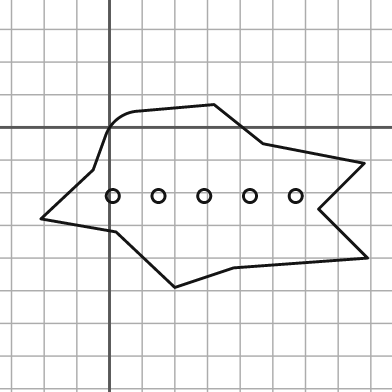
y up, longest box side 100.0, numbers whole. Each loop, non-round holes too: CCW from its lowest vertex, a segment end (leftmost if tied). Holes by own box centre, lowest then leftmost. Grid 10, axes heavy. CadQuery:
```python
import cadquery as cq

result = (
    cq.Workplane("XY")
    .moveTo(20.0, -49.0)
    .lineTo(38.0, -43.0)
    .lineTo(79.0, -40.0)
    .lineTo(64.0, -25.0)
    .lineTo(78.0, -11.0)
    .lineTo(47.0, -5.0)
    .lineTo(32.0, 7.0)
    .lineTo(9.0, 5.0)
    .threePointArc((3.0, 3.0), (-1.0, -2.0))
    .lineTo(-5.0, -13.0)
    .lineTo(-21.0, -28.0)
    .lineTo(2.0, -32.0)
    .close()
    .moveTo(1.0, -21.0)
    .circle(2.0)
    .moveTo(15.0, -21.0)
    .circle(2.0)
    .moveTo(29.0, -21.0)
    .circle(2.0)
    .moveTo(43.0, -21.0)
    .circle(2.0)
    .moveTo(57.0, -21.0)
    .circle(2.0)
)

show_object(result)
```